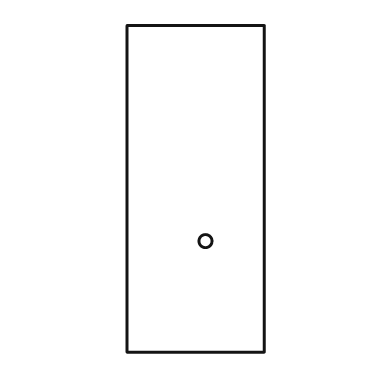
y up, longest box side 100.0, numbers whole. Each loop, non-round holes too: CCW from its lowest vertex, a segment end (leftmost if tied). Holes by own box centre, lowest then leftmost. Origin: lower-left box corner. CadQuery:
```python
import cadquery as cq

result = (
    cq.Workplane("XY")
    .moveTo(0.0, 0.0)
    .lineTo(42.0, 0.0)
    .lineTo(42.0, 100.0)
    .lineTo(0.0, 100.0)
    .close()
    .moveTo(24.0, 34.0)
    .circle(2.0)
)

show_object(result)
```